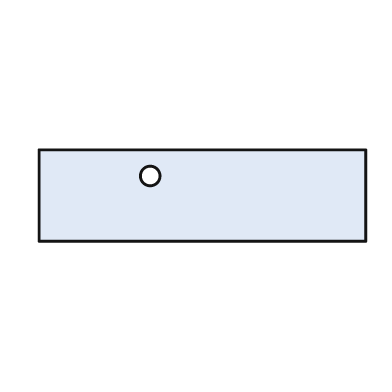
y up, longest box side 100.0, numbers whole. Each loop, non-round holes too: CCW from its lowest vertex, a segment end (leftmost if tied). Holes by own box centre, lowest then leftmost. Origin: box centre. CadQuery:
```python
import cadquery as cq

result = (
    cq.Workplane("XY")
    .moveTo(-50.0, -14.0)
    .lineTo(50.0, -14.0)
    .lineTo(50.0, 14.0)
    .lineTo(-50.0, 14.0)
    .close()
    .moveTo(-16.0, 6.0)
    .circle(3.0)
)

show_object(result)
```